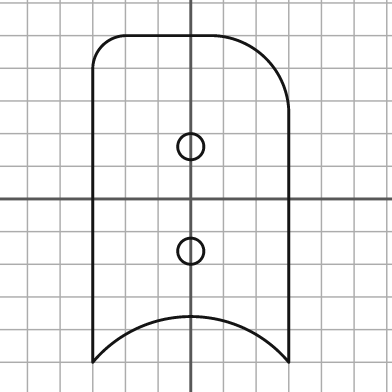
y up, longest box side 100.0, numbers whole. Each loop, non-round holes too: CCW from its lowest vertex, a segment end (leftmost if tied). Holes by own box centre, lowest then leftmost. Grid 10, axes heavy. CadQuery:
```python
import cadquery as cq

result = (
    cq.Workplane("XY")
    .moveTo(-30.0, -50.0)
    .threePointArc((0.0, -36.0), (30.0, -50.0))
    .lineTo(30.0, 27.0)
    .threePointArc((23.0, 43.0), (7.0, 50.0))
    .lineTo(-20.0, 50.0)
    .threePointArc((-27.0, 47.0), (-30.0, 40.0))
    .close()
    .moveTo(0.0, -16.0)
    .circle(4.0)
    .moveTo(0.0, 16.0)
    .circle(4.0)
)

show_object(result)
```